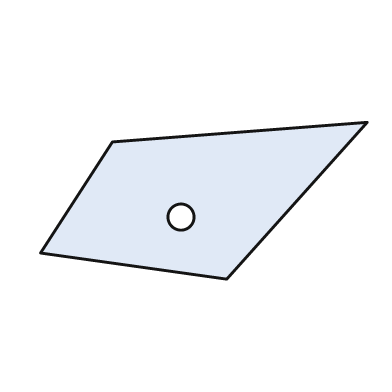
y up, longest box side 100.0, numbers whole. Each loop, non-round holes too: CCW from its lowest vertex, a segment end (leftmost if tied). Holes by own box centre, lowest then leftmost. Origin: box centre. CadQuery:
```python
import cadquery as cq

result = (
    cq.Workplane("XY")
    .moveTo(7.0, -24.0)
    .lineTo(50.0, 24.0)
    .lineTo(-28.0, 18.0)
    .lineTo(-50.0, -16.0)
    .close()
    .moveTo(-7.0, -5.0)
    .circle(4.0)
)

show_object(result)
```